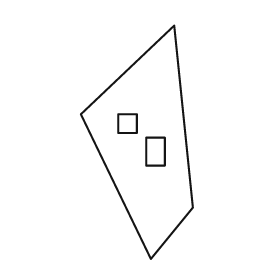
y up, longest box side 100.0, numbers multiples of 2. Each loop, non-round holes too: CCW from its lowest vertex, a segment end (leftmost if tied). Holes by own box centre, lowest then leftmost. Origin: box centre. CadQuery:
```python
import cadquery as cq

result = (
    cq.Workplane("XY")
    .moveTo(6.0, -50.0)
    .lineTo(24.0, -28.0)
    .lineTo(16.0, 50.0)
    .lineTo(-24.0, 12.0)
    .close()
    .moveTo(4.0, -10.0)
    .lineTo(12.0, -10.0)
    .lineTo(12.0, 2.0)
    .lineTo(4.0, 2.0)
    .close()
    .moveTo(-8.0, 4.0)
    .lineTo(0.0, 4.0)
    .lineTo(0.0, 12.0)
    .lineTo(-8.0, 12.0)
    .close()
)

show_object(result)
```